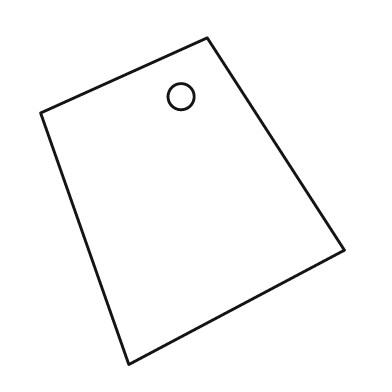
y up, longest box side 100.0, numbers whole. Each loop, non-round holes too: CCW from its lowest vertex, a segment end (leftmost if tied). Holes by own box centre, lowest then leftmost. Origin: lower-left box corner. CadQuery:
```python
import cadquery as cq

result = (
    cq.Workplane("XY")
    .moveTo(27.0, 0.0)
    .lineTo(93.0, 35.0)
    .lineTo(51.0, 100.0)
    .lineTo(0.0, 77.0)
    .close()
    .moveTo(43.0, 82.0)
    .circle(4.0)
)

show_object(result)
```